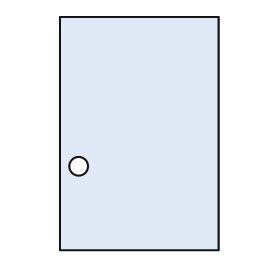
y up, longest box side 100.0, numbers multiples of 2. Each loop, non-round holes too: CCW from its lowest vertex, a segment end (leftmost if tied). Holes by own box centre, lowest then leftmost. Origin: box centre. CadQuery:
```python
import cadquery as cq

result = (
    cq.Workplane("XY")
    .moveTo(-34.0, -50.0)
    .lineTo(34.0, -50.0)
    .lineTo(34.0, 50.0)
    .lineTo(-34.0, 50.0)
    .close()
    .moveTo(-26.0, -14.0)
    .circle(4.0)
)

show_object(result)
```